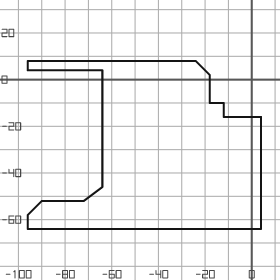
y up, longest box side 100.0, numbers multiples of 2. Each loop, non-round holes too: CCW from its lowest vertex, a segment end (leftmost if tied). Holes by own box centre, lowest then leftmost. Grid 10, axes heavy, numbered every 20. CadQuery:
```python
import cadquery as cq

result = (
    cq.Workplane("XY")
    .moveTo(-96.0, -64.0)
    .lineTo(4.0, -64.0)
    .lineTo(4.0, -16.0)
    .lineTo(-12.0, -16.0)
    .lineTo(-12.0, -10.0)
    .lineTo(-18.0, -10.0)
    .lineTo(-18.0, 2.0)
    .lineTo(-24.0, 8.0)
    .lineTo(-96.0, 8.0)
    .lineTo(-96.0, 4.0)
    .lineTo(-64.0, 4.0)
    .lineTo(-64.0, -46.0)
    .lineTo(-72.0, -52.0)
    .lineTo(-90.0, -52.0)
    .lineTo(-96.0, -58.0)
    .close()
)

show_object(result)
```